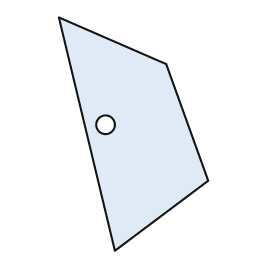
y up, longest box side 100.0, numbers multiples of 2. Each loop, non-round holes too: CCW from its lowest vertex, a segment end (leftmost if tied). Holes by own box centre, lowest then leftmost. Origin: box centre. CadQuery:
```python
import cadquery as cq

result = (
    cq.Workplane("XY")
    .moveTo(-8.0, -50.0)
    .lineTo(32.0, -20.0)
    .lineTo(14.0, 30.0)
    .lineTo(-32.0, 50.0)
    .close()
    .moveTo(-12.0, 4.0)
    .circle(4.0)
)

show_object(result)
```